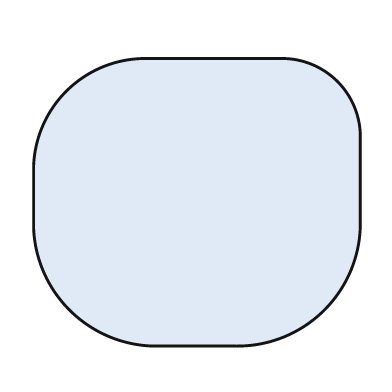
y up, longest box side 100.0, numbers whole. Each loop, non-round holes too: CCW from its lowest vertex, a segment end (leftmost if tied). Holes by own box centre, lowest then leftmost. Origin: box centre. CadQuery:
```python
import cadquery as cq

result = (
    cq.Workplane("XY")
    .moveTo(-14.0, -44.0)
    .lineTo(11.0, -44.0)
    .threePointArc((39.0, -33.0), (50.0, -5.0))
    .lineTo(50.0, 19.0)
    .threePointArc((43.0, 37.0), (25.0, 44.0))
    .lineTo(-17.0, 44.0)
    .threePointArc((-40.0, 34.0), (-50.0, 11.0))
    .lineTo(-50.0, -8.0)
    .threePointArc((-39.0, -33.0), (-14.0, -44.0))
    .close()
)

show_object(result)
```